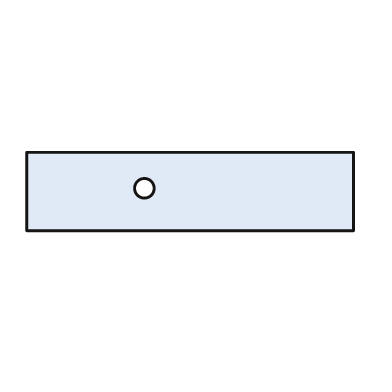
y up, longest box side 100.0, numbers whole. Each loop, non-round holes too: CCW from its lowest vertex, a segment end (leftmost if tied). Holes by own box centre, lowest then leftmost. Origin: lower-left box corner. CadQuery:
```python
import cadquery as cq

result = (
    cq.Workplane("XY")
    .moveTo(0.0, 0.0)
    .lineTo(100.0, 0.0)
    .lineTo(100.0, 24.0)
    .lineTo(0.0, 24.0)
    .close()
    .moveTo(36.0, 13.0)
    .circle(3.0)
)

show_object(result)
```